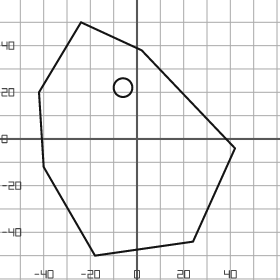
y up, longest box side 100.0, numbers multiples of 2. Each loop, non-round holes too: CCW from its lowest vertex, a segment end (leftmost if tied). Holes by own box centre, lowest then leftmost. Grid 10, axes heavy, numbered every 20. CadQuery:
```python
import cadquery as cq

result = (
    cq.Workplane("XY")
    .moveTo(-18.0, -50.0)
    .lineTo(24.0, -44.0)
    .lineTo(42.0, -4.0)
    .lineTo(2.0, 38.0)
    .lineTo(-24.0, 50.0)
    .lineTo(-42.0, 20.0)
    .lineTo(-40.0, -12.0)
    .close()
    .moveTo(-6.0, 22.0)
    .circle(4.0)
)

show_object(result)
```